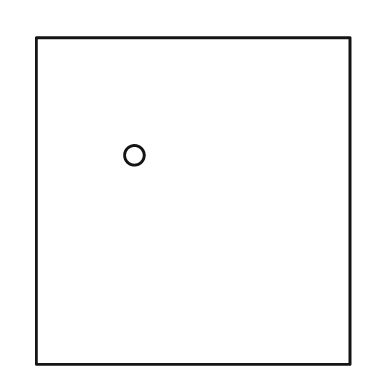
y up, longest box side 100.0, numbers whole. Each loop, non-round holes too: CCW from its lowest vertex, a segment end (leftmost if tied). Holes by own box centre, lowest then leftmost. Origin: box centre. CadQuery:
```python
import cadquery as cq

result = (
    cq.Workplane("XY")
    .moveTo(-48.0, -50.0)
    .lineTo(48.0, -50.0)
    .lineTo(48.0, 50.0)
    .lineTo(-48.0, 50.0)
    .close()
    .moveTo(-18.0, 14.0)
    .circle(3.0)
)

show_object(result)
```